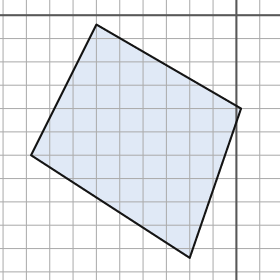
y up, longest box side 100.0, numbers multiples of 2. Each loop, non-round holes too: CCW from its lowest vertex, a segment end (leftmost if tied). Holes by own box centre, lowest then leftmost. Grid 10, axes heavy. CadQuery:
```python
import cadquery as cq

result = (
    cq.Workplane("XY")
    .moveTo(-20.0, -104.0)
    .lineTo(2.0, -40.0)
    .lineTo(-60.0, -4.0)
    .lineTo(-88.0, -60.0)
    .close()
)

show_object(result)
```